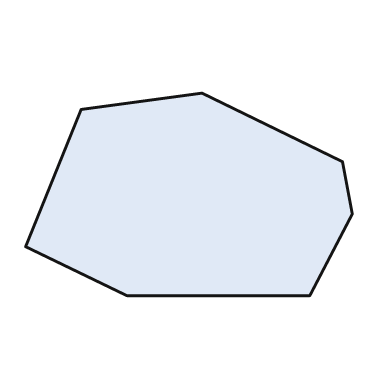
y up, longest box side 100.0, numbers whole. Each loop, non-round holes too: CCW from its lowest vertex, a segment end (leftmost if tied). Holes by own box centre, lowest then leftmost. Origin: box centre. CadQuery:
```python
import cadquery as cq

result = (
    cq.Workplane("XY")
    .moveTo(-19.0, -31.0)
    .lineTo(37.0, -31.0)
    .lineTo(50.0, -6.0)
    .lineTo(47.0, 10.0)
    .lineTo(4.0, 31.0)
    .lineTo(-33.0, 26.0)
    .lineTo(-50.0, -16.0)
    .close()
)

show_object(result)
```